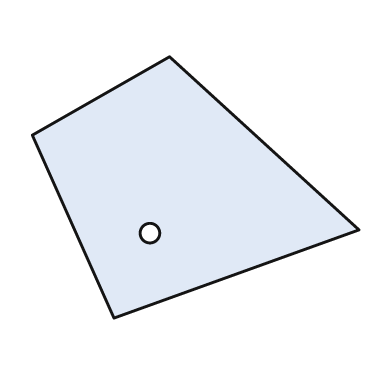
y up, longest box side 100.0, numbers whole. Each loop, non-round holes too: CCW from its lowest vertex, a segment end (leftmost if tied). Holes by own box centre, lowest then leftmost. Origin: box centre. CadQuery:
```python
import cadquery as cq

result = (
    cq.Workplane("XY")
    .moveTo(-25.0, -40.0)
    .lineTo(50.0, -13.0)
    .lineTo(-8.0, 40.0)
    .lineTo(-50.0, 16.0)
    .close()
    .moveTo(-14.0, -14.0)
    .circle(3.0)
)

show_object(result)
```